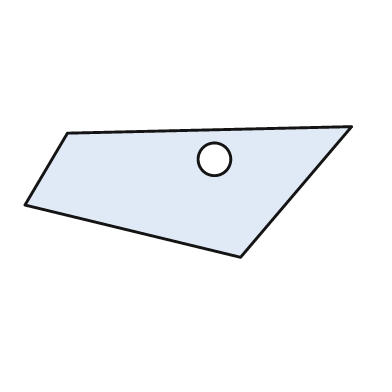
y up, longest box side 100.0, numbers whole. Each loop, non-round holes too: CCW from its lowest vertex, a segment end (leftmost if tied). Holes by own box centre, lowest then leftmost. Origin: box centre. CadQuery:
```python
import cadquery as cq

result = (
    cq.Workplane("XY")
    .moveTo(16.0, -20.0)
    .lineTo(50.0, 20.0)
    .lineTo(-37.0, 18.0)
    .lineTo(-50.0, -4.0)
    .close()
    .moveTo(8.0, 10.0)
    .circle(5.0)
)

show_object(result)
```